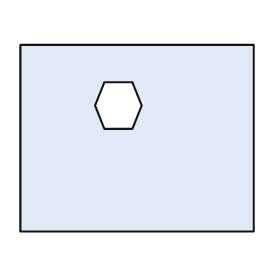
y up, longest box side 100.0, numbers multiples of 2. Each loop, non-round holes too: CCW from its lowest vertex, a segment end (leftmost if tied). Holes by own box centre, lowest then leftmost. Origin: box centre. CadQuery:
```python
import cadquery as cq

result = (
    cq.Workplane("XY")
    .moveTo(-50.0, -40.0)
    .lineTo(50.0, -40.0)
    .lineTo(50.0, 40.0)
    .lineTo(-50.0, 40.0)
    .close()
    .moveTo(-14.0, 4.0)
    .lineTo(-2.0, 4.0)
    .lineTo(2.0, 14.0)
    .lineTo(-2.0, 24.0)
    .lineTo(-14.0, 24.0)
    .lineTo(-18.0, 14.0)
    .close()
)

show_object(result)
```